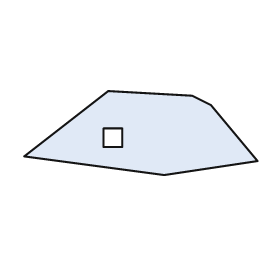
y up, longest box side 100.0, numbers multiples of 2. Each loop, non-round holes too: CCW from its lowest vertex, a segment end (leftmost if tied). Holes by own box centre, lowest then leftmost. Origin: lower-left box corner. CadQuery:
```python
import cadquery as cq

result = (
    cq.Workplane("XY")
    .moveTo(60.0, 0.0)
    .lineTo(100.0, 6.0)
    .lineTo(80.0, 30.0)
    .lineTo(72.0, 34.0)
    .lineTo(36.0, 36.0)
    .lineTo(0.0, 8.0)
    .close()
    .moveTo(34.0, 12.0)
    .lineTo(42.0, 12.0)
    .lineTo(42.0, 20.0)
    .lineTo(34.0, 20.0)
    .close()
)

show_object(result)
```